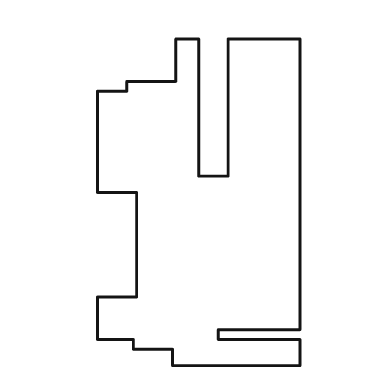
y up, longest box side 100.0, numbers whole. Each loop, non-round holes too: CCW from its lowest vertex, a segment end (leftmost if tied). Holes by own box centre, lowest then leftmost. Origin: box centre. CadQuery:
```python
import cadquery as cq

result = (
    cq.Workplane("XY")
    .moveTo(-8.0, -50.0)
    .lineTo(31.0, -50.0)
    .lineTo(31.0, -42.0)
    .lineTo(6.0, -42.0)
    .lineTo(6.0, -39.0)
    .lineTo(31.0, -39.0)
    .lineTo(31.0, 50.0)
    .lineTo(9.0, 50.0)
    .lineTo(9.0, 8.0)
    .lineTo(0.0, 8.0)
    .lineTo(0.0, 50.0)
    .lineTo(-7.0, 50.0)
    .lineTo(-7.0, 37.0)
    .lineTo(-22.0, 37.0)
    .lineTo(-22.0, 34.0)
    .lineTo(-31.0, 34.0)
    .lineTo(-31.0, 3.0)
    .lineTo(-19.0, 3.0)
    .lineTo(-19.0, -29.0)
    .lineTo(-31.0, -29.0)
    .lineTo(-31.0, -42.0)
    .lineTo(-20.0, -42.0)
    .lineTo(-20.0, -45.0)
    .lineTo(-8.0, -45.0)
    .close()
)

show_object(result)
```